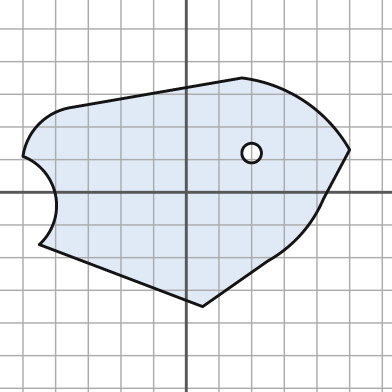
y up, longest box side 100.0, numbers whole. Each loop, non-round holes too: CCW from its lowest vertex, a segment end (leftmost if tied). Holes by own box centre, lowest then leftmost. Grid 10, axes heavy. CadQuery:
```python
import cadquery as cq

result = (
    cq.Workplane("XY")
    .moveTo(5.0, -35.0)
    .lineTo(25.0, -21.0)
    .threePointArc((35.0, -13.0), (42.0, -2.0))
    .lineTo(50.0, 13.0)
    .threePointArc((36.0, 28.0), (17.0, 35.0))
    .lineTo(-35.0, 26.0)
    .threePointArc((-45.0, 21.0), (-50.0, 11.0))
    .threePointArc((-40.0, -1.0), (-45.0, -16.0))
    .close()
    .moveTo(20.0, 12.0)
    .circle(3.0)
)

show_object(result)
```